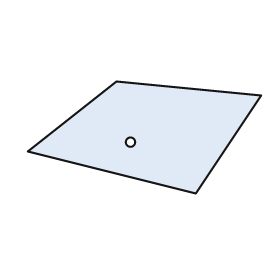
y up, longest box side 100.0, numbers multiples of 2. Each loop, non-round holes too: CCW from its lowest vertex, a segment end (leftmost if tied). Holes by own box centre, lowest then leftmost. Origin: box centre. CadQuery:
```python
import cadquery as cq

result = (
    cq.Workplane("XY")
    .moveTo(22.0, -24.0)
    .lineTo(50.0, 18.0)
    .lineTo(-12.0, 24.0)
    .lineTo(-50.0, -6.0)
    .close()
    .moveTo(-6.0, -2.0)
    .circle(2.0)
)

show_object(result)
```